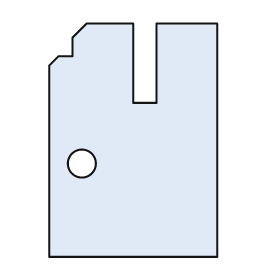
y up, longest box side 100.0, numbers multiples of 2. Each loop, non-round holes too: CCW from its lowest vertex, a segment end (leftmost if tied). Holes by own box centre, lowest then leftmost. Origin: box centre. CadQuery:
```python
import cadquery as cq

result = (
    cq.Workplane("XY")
    .moveTo(-36.0, -50.0)
    .lineTo(36.0, -50.0)
    .lineTo(36.0, 50.0)
    .lineTo(10.0, 50.0)
    .lineTo(10.0, 16.0)
    .lineTo(0.0, 16.0)
    .lineTo(0.0, 50.0)
    .lineTo(-20.0, 50.0)
    .lineTo(-26.0, 44.0)
    .lineTo(-26.0, 36.0)
    .lineTo(-32.0, 36.0)
    .lineTo(-36.0, 32.0)
    .close()
    .moveTo(-22.0, -10.0)
    .circle(6.0)
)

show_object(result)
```